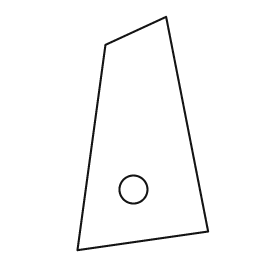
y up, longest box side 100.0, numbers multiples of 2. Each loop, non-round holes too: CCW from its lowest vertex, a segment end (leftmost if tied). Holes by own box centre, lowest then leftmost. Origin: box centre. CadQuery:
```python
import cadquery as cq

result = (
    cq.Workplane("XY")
    .moveTo(-28.0, -50.0)
    .lineTo(28.0, -42.0)
    .lineTo(10.0, 50.0)
    .lineTo(-16.0, 38.0)
    .close()
    .moveTo(-4.0, -24.0)
    .circle(6.0)
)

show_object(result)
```